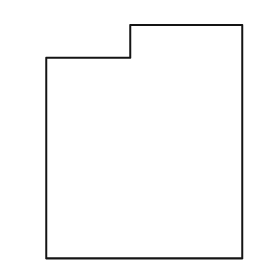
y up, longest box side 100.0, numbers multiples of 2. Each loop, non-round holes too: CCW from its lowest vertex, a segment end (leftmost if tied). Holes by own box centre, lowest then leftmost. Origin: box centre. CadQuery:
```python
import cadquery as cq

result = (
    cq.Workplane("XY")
    .moveTo(-42.0, -50.0)
    .lineTo(42.0, -50.0)
    .lineTo(42.0, 50.0)
    .lineTo(-6.0, 50.0)
    .lineTo(-6.0, 36.0)
    .lineTo(-42.0, 36.0)
    .close()
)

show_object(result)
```